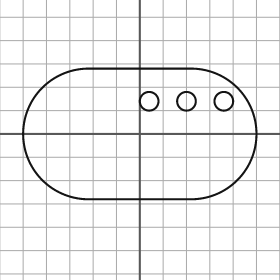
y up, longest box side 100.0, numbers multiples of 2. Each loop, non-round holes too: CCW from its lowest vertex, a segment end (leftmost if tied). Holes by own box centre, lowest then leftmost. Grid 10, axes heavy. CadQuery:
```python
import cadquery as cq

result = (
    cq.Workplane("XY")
    .moveTo(-22.0, -28.0)
    .lineTo(22.0, -28.0)
    .threePointArc((50.0, 0.0), (22.0, 28.0))
    .lineTo(-22.0, 28.0)
    .threePointArc((-50.0, 0.0), (-22.0, -28.0))
    .close()
    .moveTo(4.0, 14.0)
    .circle(4.0)
    .moveTo(20.0, 14.0)
    .circle(4.0)
    .moveTo(36.0, 14.0)
    .circle(4.0)
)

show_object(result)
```